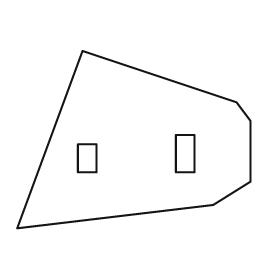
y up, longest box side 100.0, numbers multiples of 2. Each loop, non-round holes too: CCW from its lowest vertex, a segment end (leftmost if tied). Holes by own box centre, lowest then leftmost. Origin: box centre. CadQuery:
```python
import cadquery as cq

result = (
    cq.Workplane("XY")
    .moveTo(-50.0, -38.0)
    .lineTo(34.0, -28.0)
    .lineTo(50.0, -18.0)
    .lineTo(50.0, 8.0)
    .lineTo(44.0, 16.0)
    .lineTo(-22.0, 38.0)
    .close()
    .moveTo(-24.0, -14.0)
    .lineTo(-16.0, -14.0)
    .lineTo(-16.0, -2.0)
    .lineTo(-24.0, -2.0)
    .close()
    .moveTo(18.0, -14.0)
    .lineTo(26.0, -14.0)
    .lineTo(26.0, 2.0)
    .lineTo(18.0, 2.0)
    .close()
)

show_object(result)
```